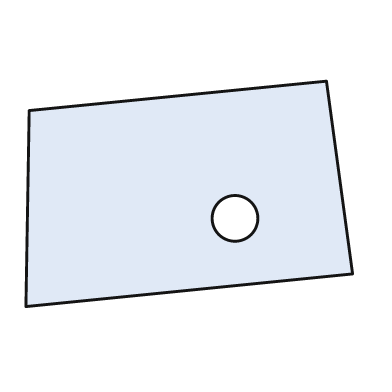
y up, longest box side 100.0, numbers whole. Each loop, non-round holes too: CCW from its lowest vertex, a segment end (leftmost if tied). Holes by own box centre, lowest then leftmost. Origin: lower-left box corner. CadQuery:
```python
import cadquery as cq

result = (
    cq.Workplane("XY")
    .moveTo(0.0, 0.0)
    .lineTo(100.0, 10.0)
    .lineTo(92.0, 69.0)
    .lineTo(1.0, 60.0)
    .close()
    .moveTo(64.0, 27.0)
    .circle(7.0)
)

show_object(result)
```